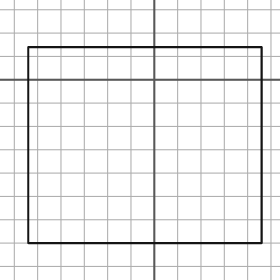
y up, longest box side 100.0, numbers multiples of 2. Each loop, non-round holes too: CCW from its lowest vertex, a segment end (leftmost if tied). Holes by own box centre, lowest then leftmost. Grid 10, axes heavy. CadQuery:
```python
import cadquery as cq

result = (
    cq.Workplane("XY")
    .moveTo(-54.0, -70.0)
    .lineTo(46.0, -70.0)
    .lineTo(46.0, 14.0)
    .lineTo(-54.0, 14.0)
    .close()
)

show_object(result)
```